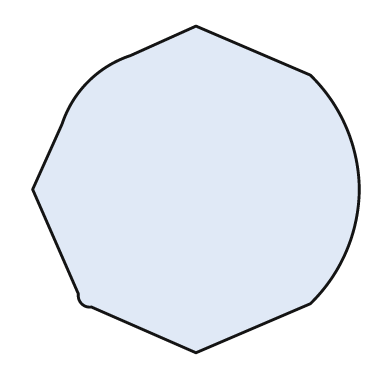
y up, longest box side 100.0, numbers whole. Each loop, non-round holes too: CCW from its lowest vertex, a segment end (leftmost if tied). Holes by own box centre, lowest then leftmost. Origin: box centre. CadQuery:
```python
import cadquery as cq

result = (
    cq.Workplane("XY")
    .moveTo(0.0, -50.0)
    .lineTo(35.0, -35.0)
    .threePointArc((46.0, -19.0), (50.0, 0.0))
    .threePointArc((46.0, 19.0), (35.0, 35.0))
    .lineTo(0.0, 50.0)
    .lineTo(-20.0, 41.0)
    .threePointArc((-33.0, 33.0), (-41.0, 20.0))
    .lineTo(-50.0, 0.0)
    .lineTo(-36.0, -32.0)
    .threePointArc((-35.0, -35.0), (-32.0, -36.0))
    .close()
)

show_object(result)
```